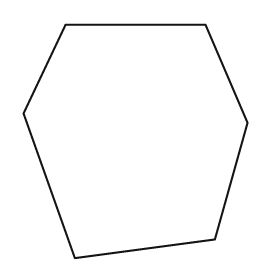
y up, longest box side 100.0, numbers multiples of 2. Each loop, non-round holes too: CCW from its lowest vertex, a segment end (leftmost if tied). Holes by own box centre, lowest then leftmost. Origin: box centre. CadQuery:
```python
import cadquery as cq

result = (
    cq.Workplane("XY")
    .moveTo(-26.0, -50.0)
    .lineTo(34.0, -42.0)
    .lineTo(48.0, 8.0)
    .lineTo(30.0, 50.0)
    .lineTo(-30.0, 50.0)
    .lineTo(-48.0, 12.0)
    .close()
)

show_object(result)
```